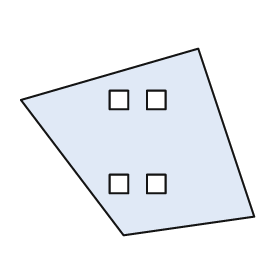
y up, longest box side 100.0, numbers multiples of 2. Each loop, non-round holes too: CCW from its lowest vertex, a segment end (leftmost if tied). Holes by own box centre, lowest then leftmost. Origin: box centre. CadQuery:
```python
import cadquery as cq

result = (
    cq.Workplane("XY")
    .moveTo(-6.0, -40.0)
    .lineTo(50.0, -32.0)
    .lineTo(26.0, 40.0)
    .lineTo(-50.0, 18.0)
    .close()
    .moveTo(-12.0, -22.0)
    .lineTo(-4.0, -22.0)
    .lineTo(-4.0, -14.0)
    .lineTo(-12.0, -14.0)
    .close()
    .moveTo(4.0, -22.0)
    .lineTo(12.0, -22.0)
    .lineTo(12.0, -14.0)
    .lineTo(4.0, -14.0)
    .close()
    .moveTo(-12.0, 14.0)
    .lineTo(-4.0, 14.0)
    .lineTo(-4.0, 22.0)
    .lineTo(-12.0, 22.0)
    .close()
    .moveTo(4.0, 14.0)
    .lineTo(12.0, 14.0)
    .lineTo(12.0, 22.0)
    .lineTo(4.0, 22.0)
    .close()
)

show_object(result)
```